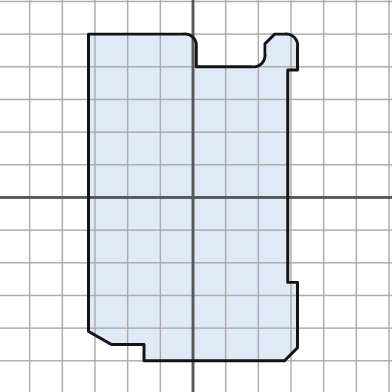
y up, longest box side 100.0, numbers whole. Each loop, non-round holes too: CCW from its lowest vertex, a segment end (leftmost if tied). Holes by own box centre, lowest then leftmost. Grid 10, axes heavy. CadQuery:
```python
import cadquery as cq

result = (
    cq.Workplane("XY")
    .moveTo(-15.0, -50.0)
    .lineTo(28.0, -50.0)
    .lineTo(32.0, -46.0)
    .lineTo(32.0, -26.0)
    .lineTo(29.0, -26.0)
    .lineTo(29.0, 39.0)
    .lineTo(32.0, 39.0)
    .lineTo(32.0, 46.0)
    .threePointArc((31.0, 49.0), (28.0, 50.0))
    .lineTo(25.0, 50.0)
    .lineTo(22.0, 47.0)
    .lineTo(22.0, 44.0)
    .threePointArc((21.0, 41.0), (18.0, 40.0))
    .lineTo(1.0, 40.0)
    .lineTo(1.0, 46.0)
    .threePointArc((0.0, 49.0), (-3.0, 50.0))
    .lineTo(-32.0, 50.0)
    .lineTo(-32.0, -41.0)
    .lineTo(-25.0, -45.0)
    .lineTo(-15.0, -45.0)
    .close()
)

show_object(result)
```